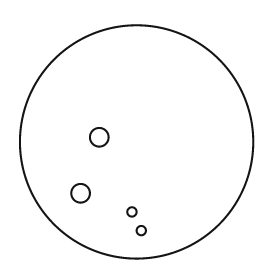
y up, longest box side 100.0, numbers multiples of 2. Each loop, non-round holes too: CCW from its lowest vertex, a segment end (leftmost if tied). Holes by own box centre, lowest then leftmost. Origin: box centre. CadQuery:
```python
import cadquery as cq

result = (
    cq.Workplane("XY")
    .moveTo(0.0, 0.0)
    .circle(50.0)
    .moveTo(2.0, -38.0)
    .circle(2.0)
    .moveTo(-2.0, -30.0)
    .circle(2.0)
    .moveTo(-24.0, -22.0)
    .circle(4.0)
    .moveTo(-16.0, 2.0)
    .circle(4.0)
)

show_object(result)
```